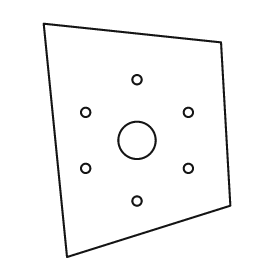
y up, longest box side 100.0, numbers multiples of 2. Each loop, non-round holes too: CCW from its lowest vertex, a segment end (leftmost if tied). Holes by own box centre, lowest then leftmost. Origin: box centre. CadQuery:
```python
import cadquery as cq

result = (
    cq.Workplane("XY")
    .moveTo(-30.0, -50.0)
    .lineTo(40.0, -28.0)
    .lineTo(36.0, 42.0)
    .lineTo(-40.0, 50.0)
    .close()
    .moveTo(0.0, -26.0)
    .circle(2.0)
    .moveTo(-22.0, -12.0)
    .circle(2.0)
    .moveTo(22.0, -12.0)
    .circle(2.0)
    .moveTo(0.0, 0.0)
    .circle(8.0)
    .moveTo(-22.0, 12.0)
    .circle(2.0)
    .moveTo(22.0, 12.0)
    .circle(2.0)
    .moveTo(0.0, 26.0)
    .circle(2.0)
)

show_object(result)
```